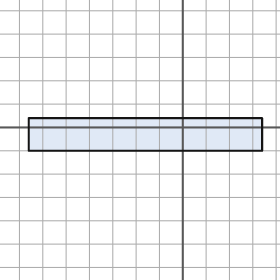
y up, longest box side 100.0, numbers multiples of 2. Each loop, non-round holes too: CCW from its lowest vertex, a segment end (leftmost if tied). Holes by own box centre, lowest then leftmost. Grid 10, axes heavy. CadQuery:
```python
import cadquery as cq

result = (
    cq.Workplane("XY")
    .moveTo(-66.0, -10.0)
    .lineTo(34.0, -10.0)
    .lineTo(34.0, 4.0)
    .lineTo(-66.0, 4.0)
    .close()
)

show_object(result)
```